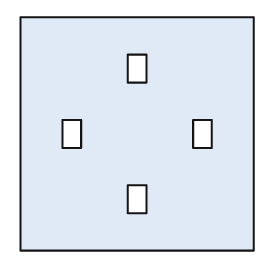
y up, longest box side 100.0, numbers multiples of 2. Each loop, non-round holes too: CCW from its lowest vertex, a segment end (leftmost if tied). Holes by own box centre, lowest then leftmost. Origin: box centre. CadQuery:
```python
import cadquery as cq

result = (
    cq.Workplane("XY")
    .moveTo(-50.0, -50.0)
    .lineTo(50.0, -50.0)
    .lineTo(50.0, 50.0)
    .lineTo(-50.0, 50.0)
    .close()
    .moveTo(-4.0, -34.0)
    .lineTo(4.0, -34.0)
    .lineTo(4.0, -22.0)
    .lineTo(-4.0, -22.0)
    .close()
    .moveTo(-32.0, -6.0)
    .lineTo(-24.0, -6.0)
    .lineTo(-24.0, 6.0)
    .lineTo(-32.0, 6.0)
    .close()
    .moveTo(24.0, -6.0)
    .lineTo(32.0, -6.0)
    .lineTo(32.0, 6.0)
    .lineTo(24.0, 6.0)
    .close()
    .moveTo(-4.0, 22.0)
    .lineTo(4.0, 22.0)
    .lineTo(4.0, 34.0)
    .lineTo(-4.0, 34.0)
    .close()
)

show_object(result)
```